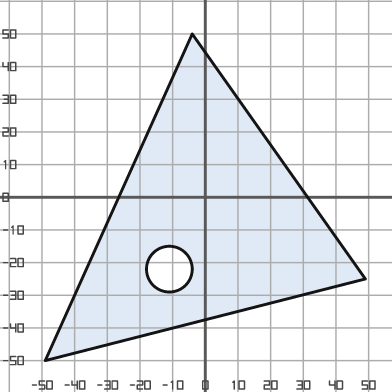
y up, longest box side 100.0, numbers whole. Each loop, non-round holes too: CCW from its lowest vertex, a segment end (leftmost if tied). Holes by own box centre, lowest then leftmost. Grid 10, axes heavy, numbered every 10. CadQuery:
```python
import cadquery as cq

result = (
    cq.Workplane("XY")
    .moveTo(-49.0, -50.0)
    .lineTo(49.0, -25.0)
    .lineTo(-4.0, 50.0)
    .close()
    .moveTo(-11.0, -22.0)
    .circle(7.0)
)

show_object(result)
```